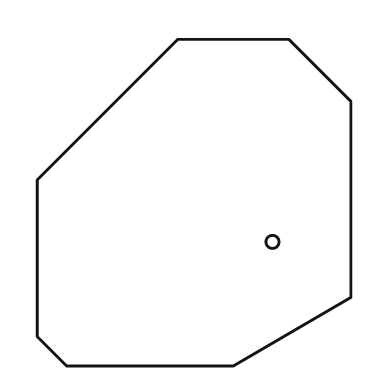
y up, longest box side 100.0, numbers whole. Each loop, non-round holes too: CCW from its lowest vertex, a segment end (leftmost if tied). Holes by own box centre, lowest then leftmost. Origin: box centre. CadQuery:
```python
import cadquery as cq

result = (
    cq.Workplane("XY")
    .moveTo(-39.0, -50.0)
    .lineTo(12.0, -50.0)
    .lineTo(48.0, -29.0)
    .lineTo(48.0, 31.0)
    .lineTo(29.0, 50.0)
    .lineTo(-5.0, 50.0)
    .lineTo(-48.0, 7.0)
    .lineTo(-48.0, -41.0)
    .close()
    .moveTo(24.0, -12.0)
    .circle(2.0)
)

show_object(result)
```